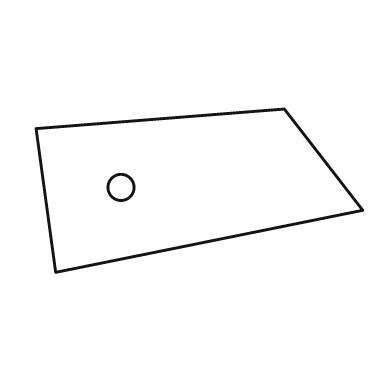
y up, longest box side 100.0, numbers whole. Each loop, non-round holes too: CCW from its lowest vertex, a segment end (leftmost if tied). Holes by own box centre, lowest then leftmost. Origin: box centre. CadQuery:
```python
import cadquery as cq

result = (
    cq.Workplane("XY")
    .moveTo(-44.0, -25.0)
    .lineTo(50.0, -6.0)
    .lineTo(26.0, 25.0)
    .lineTo(-50.0, 19.0)
    .close()
    .moveTo(-24.0, 1.0)
    .circle(4.0)
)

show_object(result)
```